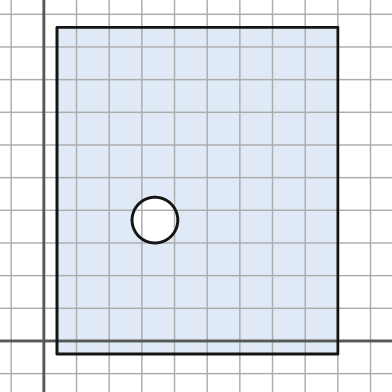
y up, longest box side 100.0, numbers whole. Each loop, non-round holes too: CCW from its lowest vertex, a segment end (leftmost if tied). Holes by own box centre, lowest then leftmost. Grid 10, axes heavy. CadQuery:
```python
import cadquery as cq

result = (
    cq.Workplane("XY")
    .moveTo(4.0, -4.0)
    .lineTo(90.0, -4.0)
    .lineTo(90.0, 96.0)
    .lineTo(4.0, 96.0)
    .close()
    .moveTo(34.0, 37.0)
    .circle(7.0)
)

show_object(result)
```